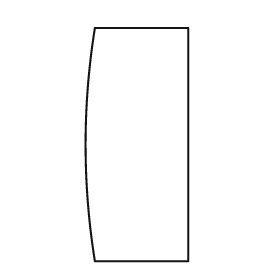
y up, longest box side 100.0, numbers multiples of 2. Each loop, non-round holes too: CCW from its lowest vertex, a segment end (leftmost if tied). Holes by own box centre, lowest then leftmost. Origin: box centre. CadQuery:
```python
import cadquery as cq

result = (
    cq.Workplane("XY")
    .moveTo(-18.0, -50.0)
    .lineTo(22.0, -50.0)
    .lineTo(22.0, 50.0)
    .lineTo(-18.0, 50.0)
    .threePointArc((-22.0, 0.0), (-18.0, -50.0))
    .close()
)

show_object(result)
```